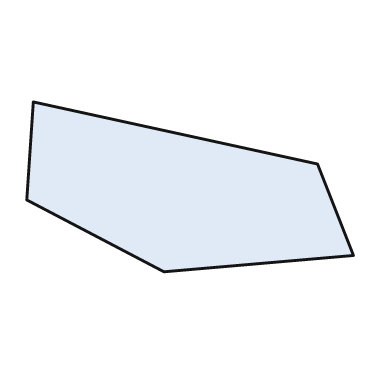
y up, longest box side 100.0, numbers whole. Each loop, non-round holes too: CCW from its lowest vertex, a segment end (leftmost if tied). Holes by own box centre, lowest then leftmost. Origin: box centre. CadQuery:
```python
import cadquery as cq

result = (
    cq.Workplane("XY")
    .moveTo(-8.0, -26.0)
    .lineTo(50.0, -21.0)
    .lineTo(39.0, 7.0)
    .lineTo(-48.0, 26.0)
    .lineTo(-50.0, -4.0)
    .close()
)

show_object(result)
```